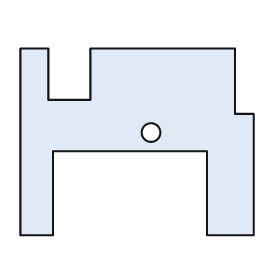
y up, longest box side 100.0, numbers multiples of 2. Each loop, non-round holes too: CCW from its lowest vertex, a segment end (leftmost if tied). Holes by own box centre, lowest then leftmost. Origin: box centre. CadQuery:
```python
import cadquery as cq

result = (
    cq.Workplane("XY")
    .moveTo(-50.0, -40.0)
    .lineTo(-36.0, -40.0)
    .lineTo(-36.0, -4.0)
    .lineTo(30.0, -4.0)
    .lineTo(30.0, -40.0)
    .lineTo(50.0, -40.0)
    .lineTo(50.0, 12.0)
    .lineTo(42.0, 12.0)
    .lineTo(42.0, 40.0)
    .lineTo(-20.0, 40.0)
    .lineTo(-20.0, 18.0)
    .lineTo(-38.0, 18.0)
    .lineTo(-38.0, 40.0)
    .lineTo(-50.0, 40.0)
    .close()
    .moveTo(6.0, 4.0)
    .circle(4.0)
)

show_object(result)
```